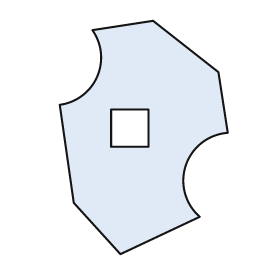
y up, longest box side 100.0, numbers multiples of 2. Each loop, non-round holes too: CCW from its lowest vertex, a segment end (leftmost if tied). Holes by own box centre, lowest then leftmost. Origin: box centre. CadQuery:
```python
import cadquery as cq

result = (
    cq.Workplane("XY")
    .moveTo(-10.0, -50.0)
    .lineTo(24.0, -34.0)
    .threePointArc((18.0, -12.0), (36.0, 2.0))
    .lineTo(32.0, 28.0)
    .lineTo(4.0, 50.0)
    .lineTo(-22.0, 46.0)
    .threePointArc((-20.0, 26.0), (-36.0, 14.0))
    .lineTo(-30.0, -28.0)
    .close()
    .moveTo(-14.0, -4.0)
    .lineTo(2.0, -4.0)
    .lineTo(2.0, 12.0)
    .lineTo(-14.0, 12.0)
    .close()
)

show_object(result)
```